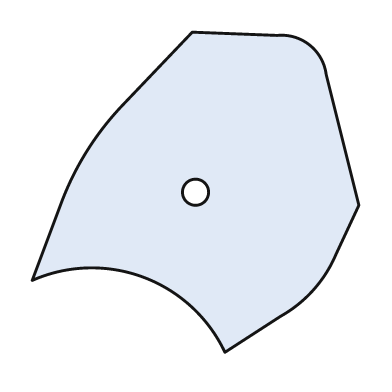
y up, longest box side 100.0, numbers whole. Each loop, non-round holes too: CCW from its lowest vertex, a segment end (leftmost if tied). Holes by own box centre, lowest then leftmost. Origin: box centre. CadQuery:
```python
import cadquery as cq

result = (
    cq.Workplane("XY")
    .moveTo(9.0, -49.0)
    .lineTo(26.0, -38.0)
    .threePointArc((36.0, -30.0), (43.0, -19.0))
    .lineTo(50.0, -4.0)
    .lineTo(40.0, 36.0)
    .threePointArc((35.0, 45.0), (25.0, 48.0))
    .lineTo(-1.0, 49.0)
    .lineTo(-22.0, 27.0)
    .threePointArc((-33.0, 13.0), (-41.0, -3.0))
    .lineTo(-50.0, -27.0)
    .threePointArc((-16.0, -26.0), (9.0, -49.0))
    .close()
    .moveTo(0.0, 0.0)
    .circle(4.0)
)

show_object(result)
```